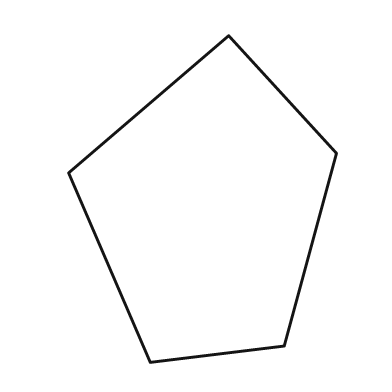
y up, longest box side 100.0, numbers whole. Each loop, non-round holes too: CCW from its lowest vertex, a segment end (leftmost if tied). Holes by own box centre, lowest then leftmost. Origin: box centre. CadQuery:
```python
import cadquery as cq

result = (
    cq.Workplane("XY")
    .moveTo(-16.0, -50.0)
    .lineTo(25.0, -45.0)
    .lineTo(41.0, 14.0)
    .lineTo(8.0, 50.0)
    .lineTo(-41.0, 8.0)
    .close()
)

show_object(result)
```